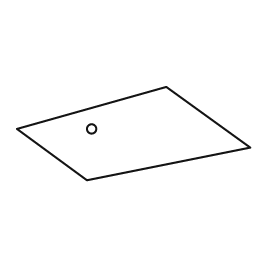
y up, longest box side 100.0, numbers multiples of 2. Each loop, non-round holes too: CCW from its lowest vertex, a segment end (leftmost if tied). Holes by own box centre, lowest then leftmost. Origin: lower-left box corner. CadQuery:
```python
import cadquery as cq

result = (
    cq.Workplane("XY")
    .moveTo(30.0, 0.0)
    .lineTo(100.0, 14.0)
    .lineTo(64.0, 40.0)
    .lineTo(0.0, 22.0)
    .close()
    .moveTo(32.0, 22.0)
    .circle(2.0)
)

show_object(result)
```